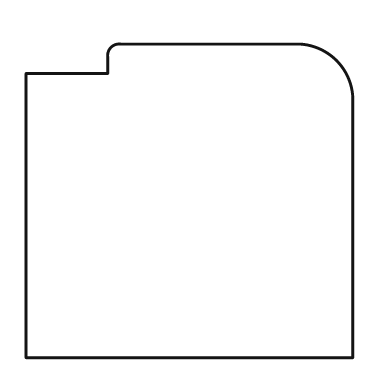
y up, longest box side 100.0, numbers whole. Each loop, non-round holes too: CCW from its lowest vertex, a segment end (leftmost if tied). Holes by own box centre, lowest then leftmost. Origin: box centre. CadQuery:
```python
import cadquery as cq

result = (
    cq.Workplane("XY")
    .moveTo(-50.0, -48.0)
    .lineTo(50.0, -48.0)
    .lineTo(50.0, 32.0)
    .threePointArc((45.0, 43.0), (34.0, 48.0))
    .lineTo(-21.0, 48.0)
    .threePointArc((-24.0, 47.0), (-25.0, 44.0))
    .lineTo(-25.0, 39.0)
    .lineTo(-50.0, 39.0)
    .close()
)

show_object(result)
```